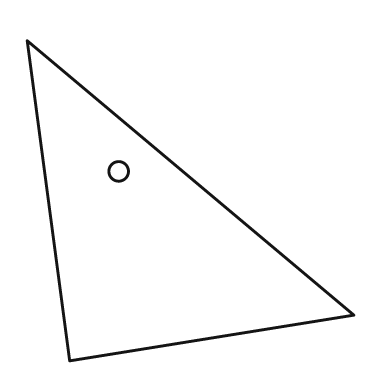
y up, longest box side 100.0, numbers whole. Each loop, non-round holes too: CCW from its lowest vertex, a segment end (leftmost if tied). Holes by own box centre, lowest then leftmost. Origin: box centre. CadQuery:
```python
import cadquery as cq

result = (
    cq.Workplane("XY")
    .moveTo(-37.0, -49.0)
    .lineTo(50.0, -35.0)
    .lineTo(-50.0, 49.0)
    .close()
    .moveTo(-22.0, 9.0)
    .circle(3.0)
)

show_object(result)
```